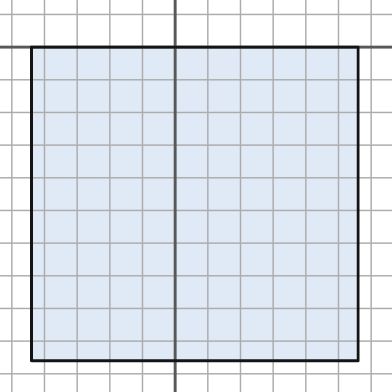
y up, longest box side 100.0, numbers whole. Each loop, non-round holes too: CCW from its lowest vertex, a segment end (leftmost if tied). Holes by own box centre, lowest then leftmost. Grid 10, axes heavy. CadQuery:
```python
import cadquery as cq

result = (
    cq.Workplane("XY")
    .moveTo(-44.0, -96.0)
    .lineTo(56.0, -96.0)
    .lineTo(56.0, 0.0)
    .lineTo(-44.0, 0.0)
    .close()
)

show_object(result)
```